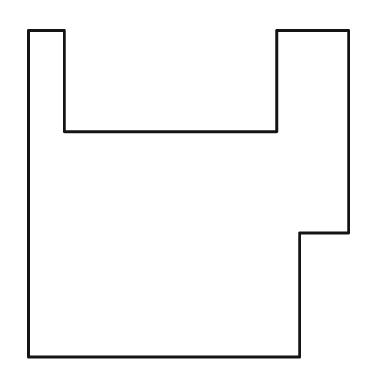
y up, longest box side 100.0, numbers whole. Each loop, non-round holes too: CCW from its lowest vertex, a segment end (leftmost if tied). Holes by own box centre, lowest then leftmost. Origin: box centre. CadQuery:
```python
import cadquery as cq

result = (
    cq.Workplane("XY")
    .moveTo(-49.0, -50.0)
    .lineTo(34.0, -50.0)
    .lineTo(34.0, -12.0)
    .lineTo(49.0, -12.0)
    .lineTo(49.0, 50.0)
    .lineTo(27.0, 50.0)
    .lineTo(27.0, 19.0)
    .lineTo(-38.0, 19.0)
    .lineTo(-38.0, 50.0)
    .lineTo(-49.0, 50.0)
    .close()
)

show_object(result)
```